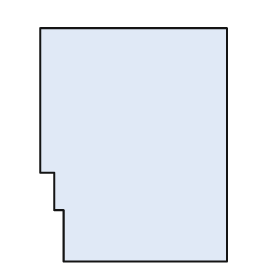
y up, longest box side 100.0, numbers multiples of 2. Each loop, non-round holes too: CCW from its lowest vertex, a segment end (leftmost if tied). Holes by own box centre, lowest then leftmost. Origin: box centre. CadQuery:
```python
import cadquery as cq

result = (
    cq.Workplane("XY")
    .moveTo(-30.0, -50.0)
    .lineTo(40.0, -50.0)
    .lineTo(40.0, 50.0)
    .lineTo(-40.0, 50.0)
    .lineTo(-40.0, -12.0)
    .lineTo(-34.0, -12.0)
    .lineTo(-34.0, -28.0)
    .lineTo(-30.0, -28.0)
    .close()
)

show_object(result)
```